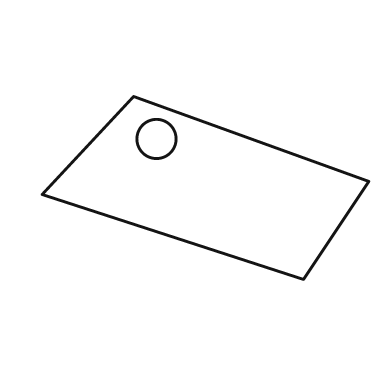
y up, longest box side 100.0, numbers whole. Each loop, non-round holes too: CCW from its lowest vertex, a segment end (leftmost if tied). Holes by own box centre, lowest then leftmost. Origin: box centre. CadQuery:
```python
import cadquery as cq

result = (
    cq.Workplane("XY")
    .moveTo(30.0, -28.0)
    .lineTo(50.0, 2.0)
    .lineTo(-22.0, 28.0)
    .lineTo(-50.0, -2.0)
    .close()
    .moveTo(-15.0, 15.0)
    .circle(6.0)
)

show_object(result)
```